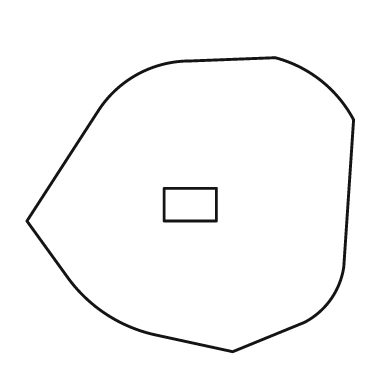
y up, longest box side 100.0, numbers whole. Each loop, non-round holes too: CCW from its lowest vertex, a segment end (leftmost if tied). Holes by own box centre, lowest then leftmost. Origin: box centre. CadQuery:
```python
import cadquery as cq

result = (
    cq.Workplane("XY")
    .moveTo(13.0, -45.0)
    .lineTo(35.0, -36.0)
    .threePointArc((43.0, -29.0), (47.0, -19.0))
    .lineTo(50.0, 26.0)
    .threePointArc((40.0, 38.0), (26.0, 45.0))
    .lineTo(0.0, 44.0)
    .threePointArc((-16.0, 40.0), (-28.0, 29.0))
    .lineTo(-50.0, -5.0)
    .lineTo(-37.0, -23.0)
    .threePointArc((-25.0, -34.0), (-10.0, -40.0))
    .close()
    .moveTo(-8.0, -5.0)
    .lineTo(8.0, -5.0)
    .lineTo(8.0, 5.0)
    .lineTo(-8.0, 5.0)
    .close()
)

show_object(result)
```